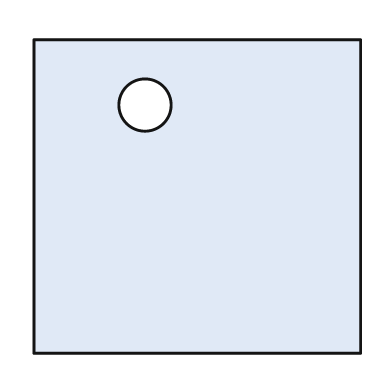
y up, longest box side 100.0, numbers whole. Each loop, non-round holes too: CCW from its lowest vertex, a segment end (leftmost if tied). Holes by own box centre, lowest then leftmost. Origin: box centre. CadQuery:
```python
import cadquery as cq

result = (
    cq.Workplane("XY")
    .moveTo(-50.0, -48.0)
    .lineTo(50.0, -48.0)
    .lineTo(50.0, 48.0)
    .lineTo(-50.0, 48.0)
    .close()
    .moveTo(-16.0, 28.0)
    .circle(8.0)
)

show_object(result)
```